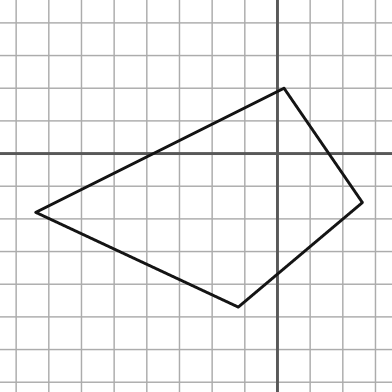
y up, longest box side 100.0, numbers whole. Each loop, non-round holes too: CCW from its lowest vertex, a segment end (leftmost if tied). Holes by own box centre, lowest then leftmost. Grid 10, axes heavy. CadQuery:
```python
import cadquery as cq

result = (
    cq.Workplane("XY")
    .moveTo(-12.0, -47.0)
    .lineTo(26.0, -15.0)
    .lineTo(2.0, 20.0)
    .lineTo(-74.0, -18.0)
    .close()
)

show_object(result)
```